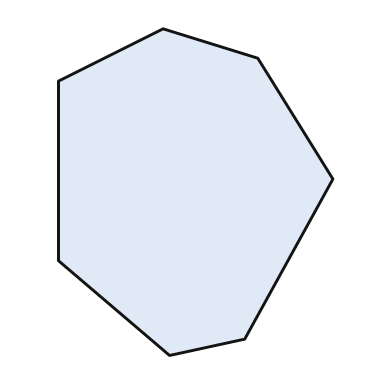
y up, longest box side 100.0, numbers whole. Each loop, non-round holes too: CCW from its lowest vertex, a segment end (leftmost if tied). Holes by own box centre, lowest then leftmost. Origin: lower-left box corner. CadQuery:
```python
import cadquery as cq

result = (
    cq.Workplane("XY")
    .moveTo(34.0, 0.0)
    .lineTo(57.0, 5.0)
    .lineTo(84.0, 54.0)
    .lineTo(61.0, 91.0)
    .lineTo(32.0, 100.0)
    .lineTo(0.0, 84.0)
    .lineTo(0.0, 29.0)
    .close()
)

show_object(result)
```